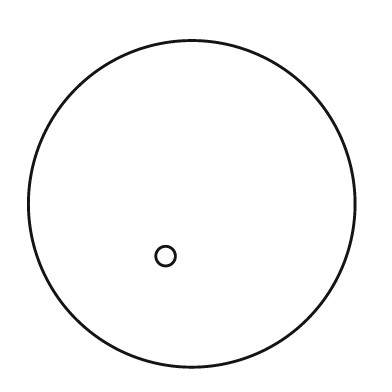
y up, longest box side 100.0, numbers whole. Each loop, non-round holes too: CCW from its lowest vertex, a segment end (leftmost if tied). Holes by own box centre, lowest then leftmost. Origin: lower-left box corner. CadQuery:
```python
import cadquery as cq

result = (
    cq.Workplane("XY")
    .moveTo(50.0, 50.0)
    .circle(50.0)
    .moveTo(42.0, 34.0)
    .circle(3.0)
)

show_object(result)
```